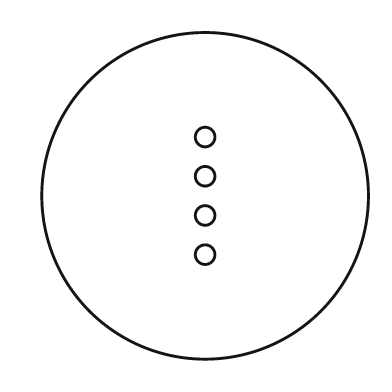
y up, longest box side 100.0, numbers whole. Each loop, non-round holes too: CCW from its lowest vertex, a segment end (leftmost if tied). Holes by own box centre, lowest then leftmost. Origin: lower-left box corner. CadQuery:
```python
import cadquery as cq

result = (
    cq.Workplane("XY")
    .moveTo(50.0, 50.0)
    .circle(50.0)
    .moveTo(50.0, 32.0)
    .circle(3.0)
    .moveTo(50.0, 44.0)
    .circle(3.0)
    .moveTo(50.0, 56.0)
    .circle(3.0)
    .moveTo(50.0, 68.0)
    .circle(3.0)
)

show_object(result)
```